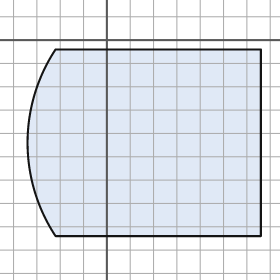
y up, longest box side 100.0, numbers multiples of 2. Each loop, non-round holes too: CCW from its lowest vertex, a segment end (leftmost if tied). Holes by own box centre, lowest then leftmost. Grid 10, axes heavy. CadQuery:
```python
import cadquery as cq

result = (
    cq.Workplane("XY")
    .moveTo(-22.0, -84.0)
    .lineTo(66.0, -84.0)
    .lineTo(66.0, -4.0)
    .lineTo(-22.0, -4.0)
    .threePointArc((-34.0, -44.0), (-22.0, -84.0))
    .close()
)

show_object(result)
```